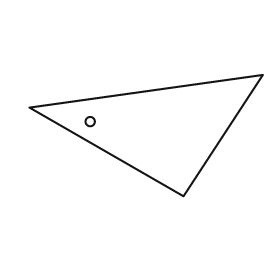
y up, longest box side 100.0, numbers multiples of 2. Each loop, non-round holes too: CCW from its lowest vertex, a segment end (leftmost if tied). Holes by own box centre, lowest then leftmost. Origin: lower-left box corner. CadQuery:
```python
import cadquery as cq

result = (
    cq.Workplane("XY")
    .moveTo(66.0, 0.0)
    .lineTo(100.0, 52.0)
    .lineTo(0.0, 38.0)
    .close()
    .moveTo(26.0, 32.0)
    .circle(2.0)
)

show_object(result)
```